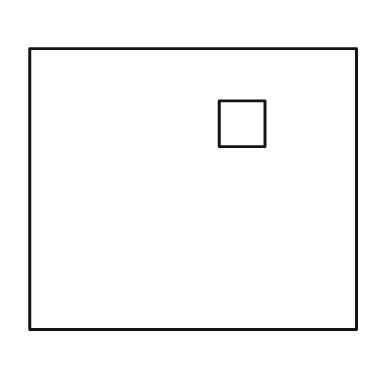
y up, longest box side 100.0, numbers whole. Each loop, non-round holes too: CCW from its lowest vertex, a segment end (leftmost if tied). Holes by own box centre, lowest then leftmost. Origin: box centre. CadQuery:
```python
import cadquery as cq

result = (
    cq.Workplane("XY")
    .moveTo(-50.0, -43.0)
    .lineTo(50.0, -43.0)
    .lineTo(50.0, 43.0)
    .lineTo(-50.0, 43.0)
    .close()
    .moveTo(8.0, 13.0)
    .lineTo(22.0, 13.0)
    .lineTo(22.0, 27.0)
    .lineTo(8.0, 27.0)
    .close()
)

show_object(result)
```